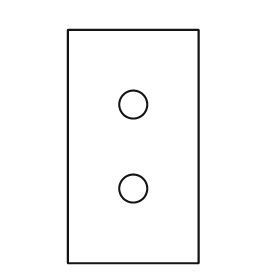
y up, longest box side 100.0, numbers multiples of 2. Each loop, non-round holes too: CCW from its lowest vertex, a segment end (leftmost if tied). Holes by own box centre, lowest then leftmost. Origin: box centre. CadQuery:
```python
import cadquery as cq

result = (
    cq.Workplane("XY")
    .moveTo(-28.0, -50.0)
    .lineTo(28.0, -50.0)
    .lineTo(28.0, 50.0)
    .lineTo(-28.0, 50.0)
    .close()
    .moveTo(0.0, -18.0)
    .circle(6.0)
    .moveTo(0.0, 18.0)
    .circle(6.0)
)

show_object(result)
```